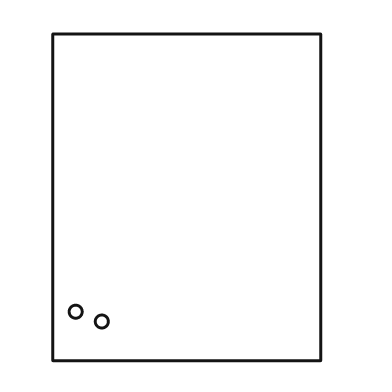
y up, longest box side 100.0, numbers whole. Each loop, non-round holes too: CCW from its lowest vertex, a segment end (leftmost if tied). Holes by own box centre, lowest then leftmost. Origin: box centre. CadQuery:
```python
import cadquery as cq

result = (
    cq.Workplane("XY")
    .moveTo(-41.0, -50.0)
    .lineTo(41.0, -50.0)
    .lineTo(41.0, 50.0)
    .lineTo(-41.0, 50.0)
    .close()
    .moveTo(-26.0, -38.0)
    .circle(2.0)
    .moveTo(-34.0, -35.0)
    .circle(2.0)
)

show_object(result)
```